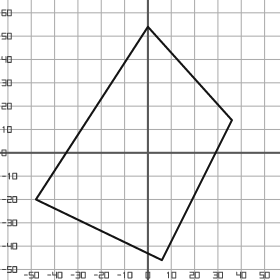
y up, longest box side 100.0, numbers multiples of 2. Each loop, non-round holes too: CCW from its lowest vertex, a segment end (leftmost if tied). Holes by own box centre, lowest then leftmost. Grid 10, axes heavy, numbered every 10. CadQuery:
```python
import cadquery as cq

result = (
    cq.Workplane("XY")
    .moveTo(6.0, -46.0)
    .lineTo(36.0, 14.0)
    .lineTo(0.0, 54.0)
    .lineTo(-48.0, -20.0)
    .close()
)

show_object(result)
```